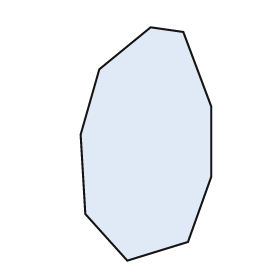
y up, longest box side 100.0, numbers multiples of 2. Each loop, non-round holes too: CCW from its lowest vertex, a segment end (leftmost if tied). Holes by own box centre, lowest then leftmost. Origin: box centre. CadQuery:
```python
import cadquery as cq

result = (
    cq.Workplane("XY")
    .moveTo(-8.0, -50.0)
    .lineTo(18.0, -42.0)
    .lineTo(28.0, -14.0)
    .lineTo(28.0, 16.0)
    .lineTo(16.0, 48.0)
    .lineTo(2.0, 50.0)
    .lineTo(-20.0, 32.0)
    .lineTo(-28.0, 4.0)
    .lineTo(-26.0, -30.0)
    .close()
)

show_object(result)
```